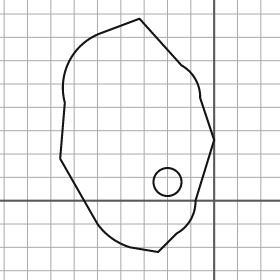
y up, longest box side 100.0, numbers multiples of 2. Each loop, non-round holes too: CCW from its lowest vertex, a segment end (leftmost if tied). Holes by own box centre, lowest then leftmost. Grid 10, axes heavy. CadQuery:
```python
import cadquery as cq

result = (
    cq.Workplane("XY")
    .moveTo(-24.0, -22.0)
    .lineTo(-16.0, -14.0)
    .threePointArc((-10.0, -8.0), (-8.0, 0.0))
    .lineTo(0.0, 26.0)
    .lineTo(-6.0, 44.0)
    .threePointArc((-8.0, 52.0), (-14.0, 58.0))
    .lineTo(-32.0, 78.0)
    .lineTo(-48.0, 72.0)
    .threePointArc((-62.0, 60.0), (-64.0, 42.0))
    .lineTo(-66.0, 18.0)
    .lineTo(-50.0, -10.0)
    .threePointArc((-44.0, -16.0), (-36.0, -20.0))
    .close()
    .moveTo(-20.0, 8.0)
    .circle(6.0)
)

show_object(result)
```